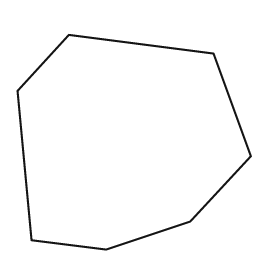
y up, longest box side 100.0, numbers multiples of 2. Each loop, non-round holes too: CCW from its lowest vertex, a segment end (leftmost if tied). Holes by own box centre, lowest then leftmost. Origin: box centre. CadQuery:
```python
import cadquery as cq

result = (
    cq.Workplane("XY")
    .moveTo(-12.0, -46.0)
    .lineTo(24.0, -34.0)
    .lineTo(50.0, -6.0)
    .lineTo(34.0, 38.0)
    .lineTo(-28.0, 46.0)
    .lineTo(-50.0, 22.0)
    .lineTo(-44.0, -42.0)
    .close()
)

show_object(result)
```